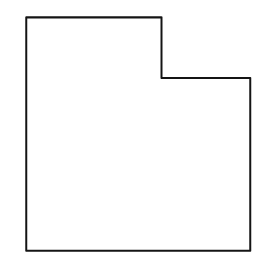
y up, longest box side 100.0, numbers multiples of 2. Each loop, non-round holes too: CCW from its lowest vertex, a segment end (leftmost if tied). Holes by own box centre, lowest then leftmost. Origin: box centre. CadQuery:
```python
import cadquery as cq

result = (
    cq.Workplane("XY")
    .moveTo(-48.0, -50.0)
    .lineTo(48.0, -50.0)
    .lineTo(48.0, 24.0)
    .lineTo(10.0, 24.0)
    .lineTo(10.0, 50.0)
    .lineTo(-48.0, 50.0)
    .close()
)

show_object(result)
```